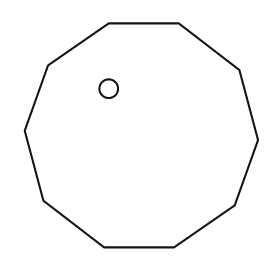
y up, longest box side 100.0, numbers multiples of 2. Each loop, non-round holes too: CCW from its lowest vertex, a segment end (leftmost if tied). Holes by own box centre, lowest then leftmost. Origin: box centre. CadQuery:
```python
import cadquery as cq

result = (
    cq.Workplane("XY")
    .moveTo(-16.0, -48.0)
    .lineTo(14.0, -48.0)
    .lineTo(40.0, -30.0)
    .lineTo(50.0, -2.0)
    .lineTo(42.0, 28.0)
    .lineTo(16.0, 48.0)
    .lineTo(-14.0, 48.0)
    .lineTo(-40.0, 30.0)
    .lineTo(-50.0, 2.0)
    .lineTo(-42.0, -28.0)
    .close()
    .moveTo(-14.0, 20.0)
    .circle(4.0)
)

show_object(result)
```